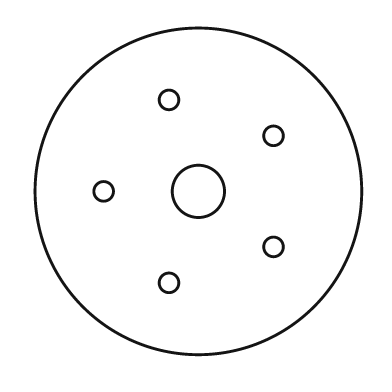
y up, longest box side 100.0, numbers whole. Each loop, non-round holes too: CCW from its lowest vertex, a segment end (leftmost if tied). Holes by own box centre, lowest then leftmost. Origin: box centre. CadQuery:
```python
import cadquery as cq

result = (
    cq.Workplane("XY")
    .moveTo(0.0, 0.0)
    .circle(50.0)
    .moveTo(-9.0, -28.0)
    .circle(3.0)
    .moveTo(23.0, -17.0)
    .circle(3.0)
    .moveTo(-29.0, 0.0)
    .circle(3.0)
    .moveTo(0.0, 0.0)
    .circle(8.0)
    .moveTo(23.0, 17.0)
    .circle(3.0)
    .moveTo(-9.0, 28.0)
    .circle(3.0)
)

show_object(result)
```